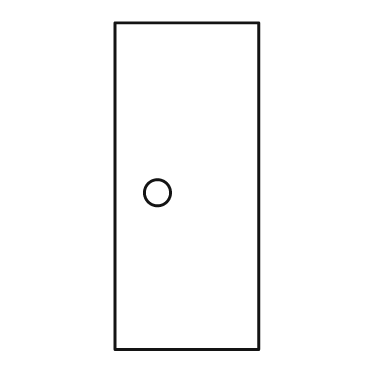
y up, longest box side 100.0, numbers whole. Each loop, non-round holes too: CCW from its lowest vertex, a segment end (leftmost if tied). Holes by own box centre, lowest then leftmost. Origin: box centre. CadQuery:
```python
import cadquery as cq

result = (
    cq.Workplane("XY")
    .moveTo(-22.0, -50.0)
    .lineTo(22.0, -50.0)
    .lineTo(22.0, 50.0)
    .lineTo(-22.0, 50.0)
    .close()
    .moveTo(-9.0, -2.0)
    .circle(4.0)
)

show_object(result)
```